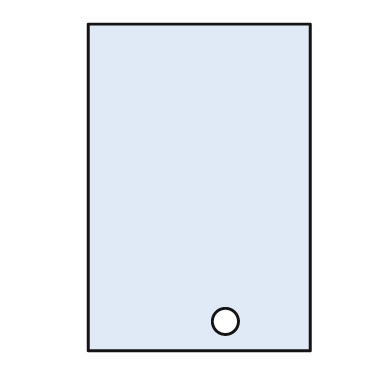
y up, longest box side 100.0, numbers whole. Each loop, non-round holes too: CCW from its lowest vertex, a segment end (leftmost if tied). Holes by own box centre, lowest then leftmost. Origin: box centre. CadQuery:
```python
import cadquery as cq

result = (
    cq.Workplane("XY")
    .moveTo(-34.0, -50.0)
    .lineTo(34.0, -50.0)
    .lineTo(34.0, 50.0)
    .lineTo(-34.0, 50.0)
    .close()
    .moveTo(8.0, -41.0)
    .circle(4.0)
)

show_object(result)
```